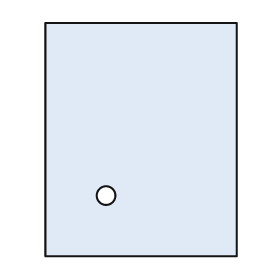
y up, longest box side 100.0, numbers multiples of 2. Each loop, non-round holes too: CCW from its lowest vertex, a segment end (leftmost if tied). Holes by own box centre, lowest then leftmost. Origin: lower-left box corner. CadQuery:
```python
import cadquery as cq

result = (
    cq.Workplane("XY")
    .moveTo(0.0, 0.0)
    .lineTo(82.0, 0.0)
    .lineTo(82.0, 100.0)
    .lineTo(0.0, 100.0)
    .close()
    .moveTo(26.0, 26.0)
    .circle(4.0)
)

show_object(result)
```